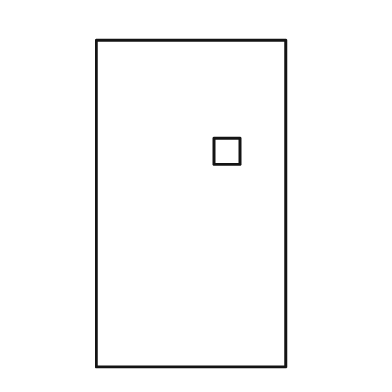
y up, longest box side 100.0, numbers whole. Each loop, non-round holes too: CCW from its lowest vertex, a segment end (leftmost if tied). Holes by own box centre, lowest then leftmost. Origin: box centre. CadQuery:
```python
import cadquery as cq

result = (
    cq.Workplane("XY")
    .moveTo(-29.0, -50.0)
    .lineTo(29.0, -50.0)
    .lineTo(29.0, 50.0)
    .lineTo(-29.0, 50.0)
    .close()
    .moveTo(7.0, 12.0)
    .lineTo(15.0, 12.0)
    .lineTo(15.0, 20.0)
    .lineTo(7.0, 20.0)
    .close()
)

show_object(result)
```